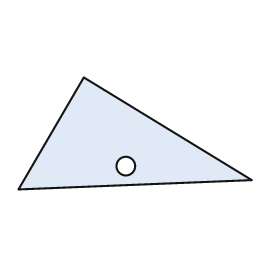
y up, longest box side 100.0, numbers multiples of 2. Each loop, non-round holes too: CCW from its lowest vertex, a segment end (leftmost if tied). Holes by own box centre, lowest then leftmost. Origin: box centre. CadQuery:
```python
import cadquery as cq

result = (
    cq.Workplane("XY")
    .moveTo(-50.0, -24.0)
    .lineTo(50.0, -20.0)
    .lineTo(-22.0, 24.0)
    .close()
    .moveTo(-4.0, -14.0)
    .circle(4.0)
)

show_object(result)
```